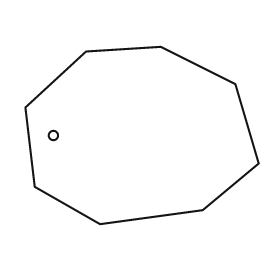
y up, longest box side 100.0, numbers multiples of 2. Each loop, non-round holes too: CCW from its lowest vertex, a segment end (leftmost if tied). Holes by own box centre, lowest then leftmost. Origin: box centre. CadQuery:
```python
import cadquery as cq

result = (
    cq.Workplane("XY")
    .moveTo(-18.0, -38.0)
    .lineTo(26.0, -32.0)
    .lineTo(50.0, -12.0)
    .lineTo(40.0, 22.0)
    .lineTo(8.0, 38.0)
    .lineTo(-24.0, 36.0)
    .lineTo(-50.0, 12.0)
    .lineTo(-46.0, -22.0)
    .close()
    .moveTo(-38.0, 0.0)
    .circle(2.0)
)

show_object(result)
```